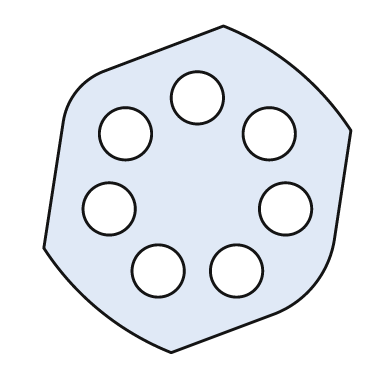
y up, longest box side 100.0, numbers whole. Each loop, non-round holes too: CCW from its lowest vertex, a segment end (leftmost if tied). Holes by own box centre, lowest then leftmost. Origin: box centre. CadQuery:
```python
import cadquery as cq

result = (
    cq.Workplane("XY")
    .moveTo(-8.0, -50.0)
    .lineTo(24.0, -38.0)
    .threePointArc((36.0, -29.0), (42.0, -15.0))
    .lineTo(47.0, 18.0)
    .threePointArc((30.0, 37.0), (8.0, 50.0))
    .lineTo(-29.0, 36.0)
    .threePointArc((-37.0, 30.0), (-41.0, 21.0))
    .lineTo(-47.0, -18.0)
    .threePointArc((-30.0, -37.0), (-8.0, -50.0))
    .close()
    .moveTo(-12.0, -25.0)
    .circle(8.0)
    .moveTo(12.0, -25.0)
    .circle(8.0)
    .moveTo(-27.0, -6.0)
    .circle(8.0)
    .moveTo(27.0, -6.0)
    .circle(8.0)
    .moveTo(-22.0, 17.0)
    .circle(8.0)
    .moveTo(22.0, 17.0)
    .circle(8.0)
    .moveTo(0.0, 28.0)
    .circle(8.0)
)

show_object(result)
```